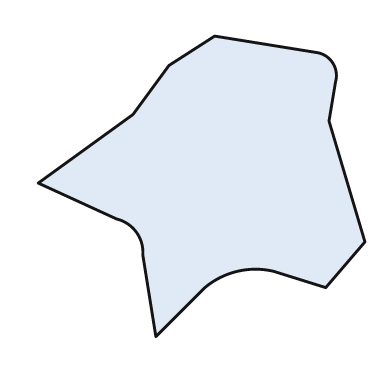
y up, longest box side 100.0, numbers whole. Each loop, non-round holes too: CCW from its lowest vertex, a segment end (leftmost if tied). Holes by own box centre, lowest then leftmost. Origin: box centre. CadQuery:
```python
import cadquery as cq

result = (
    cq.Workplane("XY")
    .moveTo(-14.0, -46.0)
    .lineTo(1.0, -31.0)
    .threePointArc((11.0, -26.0), (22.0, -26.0))
    .lineTo(38.0, -31.0)
    .lineTo(50.0, -17.0)
    .lineTo(39.0, 20.0)
    .lineTo(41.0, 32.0)
    .threePointArc((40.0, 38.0), (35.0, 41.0))
    .lineTo(4.0, 46.0)
    .lineTo(-10.0, 37.0)
    .lineTo(-21.0, 22.0)
    .lineTo(-50.0, 1.0)
    .lineTo(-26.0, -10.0)
    .threePointArc((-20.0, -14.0), (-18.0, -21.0))
    .close()
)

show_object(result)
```